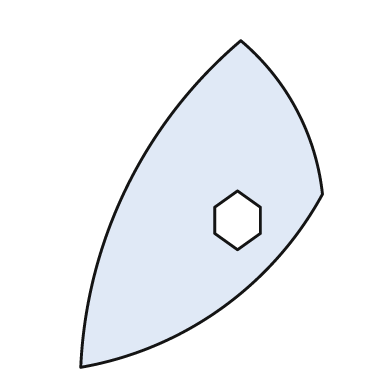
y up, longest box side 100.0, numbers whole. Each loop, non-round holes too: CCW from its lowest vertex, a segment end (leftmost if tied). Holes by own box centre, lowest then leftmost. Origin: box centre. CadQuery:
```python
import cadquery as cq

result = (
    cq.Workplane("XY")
    .moveTo(-37.0, -50.0)
    .threePointArc((6.0, -32.0), (37.0, 3.0))
    .threePointArc((29.0, 29.0), (12.0, 50.0))
    .threePointArc((-23.0, 5.0), (-37.0, -50.0))
    .close()
    .moveTo(11.0, -14.0)
    .lineTo(18.0, -9.0)
    .lineTo(18.0, -1.0)
    .lineTo(11.0, 4.0)
    .lineTo(4.0, -1.0)
    .lineTo(4.0, -9.0)
    .close()
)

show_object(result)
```